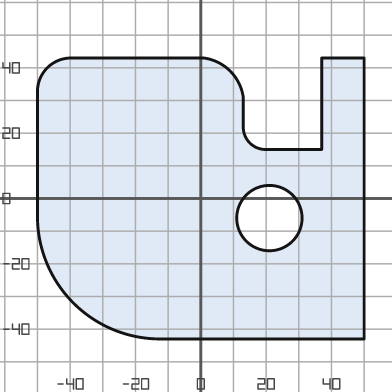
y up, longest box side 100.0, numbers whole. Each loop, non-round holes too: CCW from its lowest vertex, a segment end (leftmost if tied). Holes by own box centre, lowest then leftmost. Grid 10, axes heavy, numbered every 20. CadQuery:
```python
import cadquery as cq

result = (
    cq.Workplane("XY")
    .moveTo(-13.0, -43.0)
    .lineTo(50.0, -43.0)
    .lineTo(50.0, 43.0)
    .lineTo(37.0, 43.0)
    .lineTo(37.0, 15.0)
    .lineTo(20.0, 15.0)
    .threePointArc((15.0, 17.0), (13.0, 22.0))
    .lineTo(13.0, 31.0)
    .threePointArc((9.0, 39.0), (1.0, 43.0))
    .lineTo(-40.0, 43.0)
    .threePointArc((-47.0, 40.0), (-50.0, 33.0))
    .lineTo(-50.0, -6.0)
    .threePointArc((-39.0, -32.0), (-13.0, -43.0))
    .close()
    .moveTo(21.0, -6.0)
    .circle(10.0)
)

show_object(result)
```